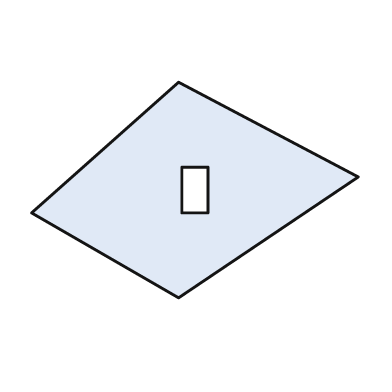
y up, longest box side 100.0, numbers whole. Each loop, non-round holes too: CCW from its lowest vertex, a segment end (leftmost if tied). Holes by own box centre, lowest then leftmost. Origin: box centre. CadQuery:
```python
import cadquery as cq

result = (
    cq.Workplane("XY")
    .moveTo(-5.0, -33.0)
    .lineTo(50.0, 4.0)
    .lineTo(-5.0, 33.0)
    .lineTo(-50.0, -7.0)
    .close()
    .moveTo(-4.0, -7.0)
    .lineTo(4.0, -7.0)
    .lineTo(4.0, 7.0)
    .lineTo(-4.0, 7.0)
    .close()
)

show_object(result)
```